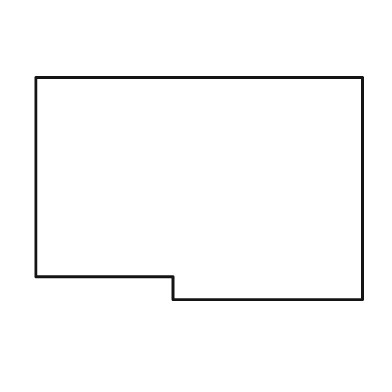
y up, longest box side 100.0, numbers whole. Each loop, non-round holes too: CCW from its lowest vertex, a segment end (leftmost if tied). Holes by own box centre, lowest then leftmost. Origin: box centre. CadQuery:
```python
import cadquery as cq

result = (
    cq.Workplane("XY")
    .moveTo(-8.0, -34.0)
    .lineTo(50.0, -34.0)
    .lineTo(50.0, 34.0)
    .lineTo(-50.0, 34.0)
    .lineTo(-50.0, -27.0)
    .lineTo(-8.0, -27.0)
    .close()
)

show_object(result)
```